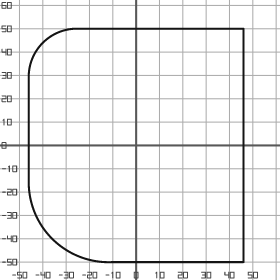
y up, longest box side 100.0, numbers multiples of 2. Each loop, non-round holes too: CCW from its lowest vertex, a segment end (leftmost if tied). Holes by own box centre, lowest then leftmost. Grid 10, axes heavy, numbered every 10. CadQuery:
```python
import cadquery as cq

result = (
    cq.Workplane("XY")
    .moveTo(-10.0, -50.0)
    .lineTo(46.0, -50.0)
    .lineTo(46.0, 50.0)
    .lineTo(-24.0, 50.0)
    .threePointArc((-40.0, 44.0), (-46.0, 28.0))
    .lineTo(-46.0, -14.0)
    .threePointArc((-36.0, -40.0), (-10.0, -50.0))
    .close()
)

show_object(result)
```